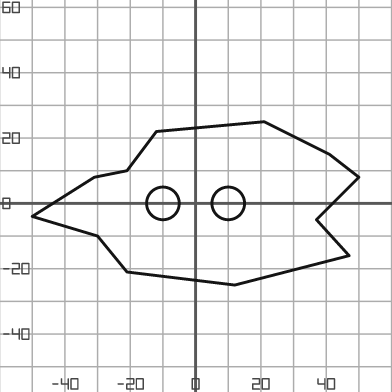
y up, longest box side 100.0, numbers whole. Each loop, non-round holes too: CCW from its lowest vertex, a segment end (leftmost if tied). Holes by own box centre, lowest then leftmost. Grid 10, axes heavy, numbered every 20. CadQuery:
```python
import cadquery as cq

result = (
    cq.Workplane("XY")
    .moveTo(12.0, -25.0)
    .lineTo(47.0, -16.0)
    .lineTo(37.0, -5.0)
    .lineTo(50.0, 8.0)
    .lineTo(41.0, 15.0)
    .lineTo(21.0, 25.0)
    .lineTo(-12.0, 22.0)
    .lineTo(-21.0, 10.0)
    .lineTo(-31.0, 8.0)
    .lineTo(-50.0, -4.0)
    .lineTo(-30.0, -10.0)
    .lineTo(-21.0, -21.0)
    .close()
    .moveTo(-10.0, 0.0)
    .circle(5.0)
    .moveTo(10.0, 0.0)
    .circle(5.0)
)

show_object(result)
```